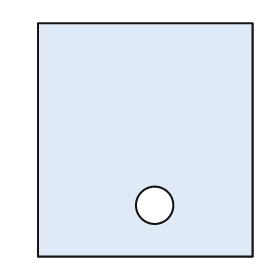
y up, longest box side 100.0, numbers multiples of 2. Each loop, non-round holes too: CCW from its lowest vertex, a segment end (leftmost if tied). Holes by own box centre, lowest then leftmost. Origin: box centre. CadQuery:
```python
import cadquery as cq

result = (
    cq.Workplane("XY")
    .moveTo(-46.0, -50.0)
    .lineTo(46.0, -50.0)
    .lineTo(46.0, 50.0)
    .lineTo(-46.0, 50.0)
    .close()
    .moveTo(4.0, -28.0)
    .circle(8.0)
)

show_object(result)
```